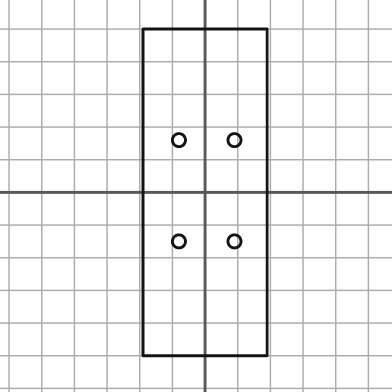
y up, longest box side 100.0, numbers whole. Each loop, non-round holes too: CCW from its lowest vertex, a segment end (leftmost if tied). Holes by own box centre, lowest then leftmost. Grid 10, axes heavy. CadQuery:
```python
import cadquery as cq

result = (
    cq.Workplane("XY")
    .moveTo(-19.0, -50.0)
    .lineTo(19.0, -50.0)
    .lineTo(19.0, 50.0)
    .lineTo(-19.0, 50.0)
    .close()
    .moveTo(-8.0, -15.0)
    .circle(2.0)
    .moveTo(9.0, -15.0)
    .circle(2.0)
    .moveTo(-8.0, 16.0)
    .circle(2.0)
    .moveTo(9.0, 16.0)
    .circle(2.0)
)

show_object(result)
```